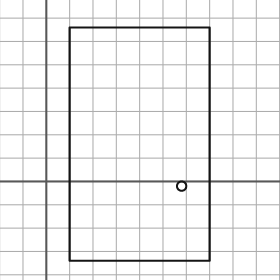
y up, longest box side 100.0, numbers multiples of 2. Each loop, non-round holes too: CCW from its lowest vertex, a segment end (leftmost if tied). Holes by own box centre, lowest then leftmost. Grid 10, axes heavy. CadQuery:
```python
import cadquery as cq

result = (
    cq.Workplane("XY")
    .moveTo(10.0, -34.0)
    .lineTo(70.0, -34.0)
    .lineTo(70.0, 66.0)
    .lineTo(10.0, 66.0)
    .close()
    .moveTo(58.0, -2.0)
    .circle(2.0)
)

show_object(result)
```